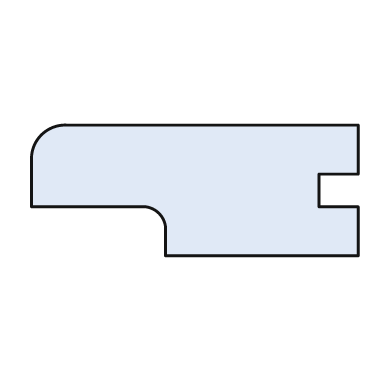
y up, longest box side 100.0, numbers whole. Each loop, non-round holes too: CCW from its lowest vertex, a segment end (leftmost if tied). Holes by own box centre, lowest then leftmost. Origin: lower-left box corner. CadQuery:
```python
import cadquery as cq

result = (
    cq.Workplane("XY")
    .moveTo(41.0, 0.0)
    .lineTo(100.0, 0.0)
    .lineTo(100.0, 15.0)
    .lineTo(88.0, 15.0)
    .lineTo(88.0, 25.0)
    .lineTo(100.0, 25.0)
    .lineTo(100.0, 40.0)
    .lineTo(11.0, 40.0)
    .threePointArc((3.0, 37.0), (0.0, 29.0))
    .lineTo(0.0, 15.0)
    .lineTo(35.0, 15.0)
    .threePointArc((39.0, 13.0), (41.0, 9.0))
    .close()
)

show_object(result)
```